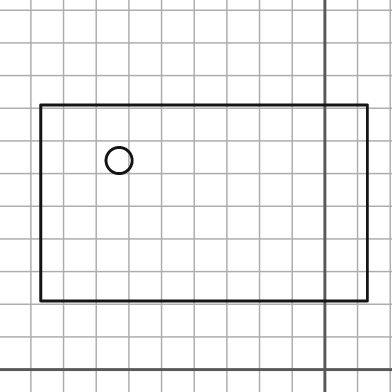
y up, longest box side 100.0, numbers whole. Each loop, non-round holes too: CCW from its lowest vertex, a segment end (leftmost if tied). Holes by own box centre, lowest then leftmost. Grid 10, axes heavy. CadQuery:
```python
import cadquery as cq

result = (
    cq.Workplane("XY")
    .moveTo(-87.0, 21.0)
    .lineTo(13.0, 21.0)
    .lineTo(13.0, 81.0)
    .lineTo(-87.0, 81.0)
    .close()
    .moveTo(-63.0, 64.0)
    .circle(4.0)
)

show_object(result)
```